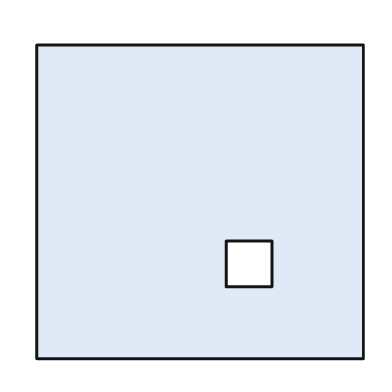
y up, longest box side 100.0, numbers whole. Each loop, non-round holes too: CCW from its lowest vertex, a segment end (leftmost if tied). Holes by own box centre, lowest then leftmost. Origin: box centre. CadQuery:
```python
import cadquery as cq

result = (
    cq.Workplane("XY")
    .moveTo(-50.0, -48.0)
    .lineTo(50.0, -48.0)
    .lineTo(50.0, 48.0)
    .lineTo(-50.0, 48.0)
    .close()
    .moveTo(8.0, -26.0)
    .lineTo(22.0, -26.0)
    .lineTo(22.0, -12.0)
    .lineTo(8.0, -12.0)
    .close()
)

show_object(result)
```